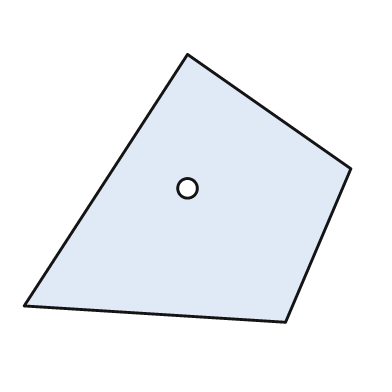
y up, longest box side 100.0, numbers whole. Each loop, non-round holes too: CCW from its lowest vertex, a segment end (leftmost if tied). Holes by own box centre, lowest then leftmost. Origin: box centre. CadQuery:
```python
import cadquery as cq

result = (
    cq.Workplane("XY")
    .moveTo(30.0, -41.0)
    .lineTo(50.0, 6.0)
    .lineTo(0.0, 41.0)
    .lineTo(-50.0, -36.0)
    .close()
    .moveTo(0.0, 0.0)
    .circle(3.0)
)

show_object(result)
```